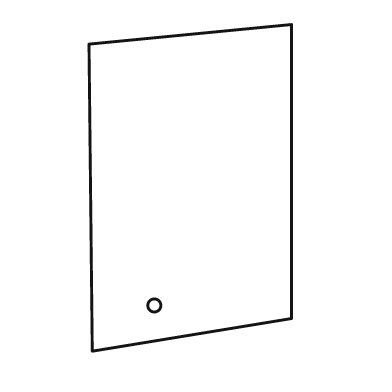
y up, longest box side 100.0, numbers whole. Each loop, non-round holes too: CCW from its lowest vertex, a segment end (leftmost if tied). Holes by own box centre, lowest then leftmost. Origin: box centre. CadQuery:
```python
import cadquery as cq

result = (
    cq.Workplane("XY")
    .moveTo(-30.0, -50.0)
    .lineTo(31.0, -40.0)
    .lineTo(31.0, 50.0)
    .lineTo(-31.0, 44.0)
    .close()
    .moveTo(-11.0, -36.0)
    .circle(2.0)
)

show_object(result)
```